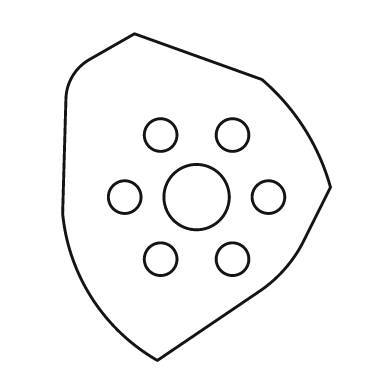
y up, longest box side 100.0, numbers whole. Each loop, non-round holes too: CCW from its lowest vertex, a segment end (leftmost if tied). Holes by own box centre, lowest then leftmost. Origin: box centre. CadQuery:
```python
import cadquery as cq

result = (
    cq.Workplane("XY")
    .moveTo(-12.0, -50.0)
    .lineTo(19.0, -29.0)
    .threePointArc((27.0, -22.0), (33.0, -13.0))
    .lineTo(41.0, 3.0)
    .threePointArc((33.0, 21.0), (20.0, 36.0))
    .lineTo(-19.0, 50.0)
    .lineTo(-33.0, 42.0)
    .threePointArc((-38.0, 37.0), (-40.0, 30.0))
    .lineTo(-41.0, -5.0)
    .threePointArc((-32.0, -31.0), (-12.0, -50.0))
    .close()
    .moveTo(-11.0, -19.0)
    .circle(5.0)
    .moveTo(11.0, -19.0)
    .circle(5.0)
    .moveTo(-22.0, 0.0)
    .circle(5.0)
    .moveTo(0.0, 0.0)
    .circle(10.0)
    .moveTo(22.0, 0.0)
    .circle(5.0)
    .moveTo(-11.0, 19.0)
    .circle(5.0)
    .moveTo(11.0, 19.0)
    .circle(5.0)
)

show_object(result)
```